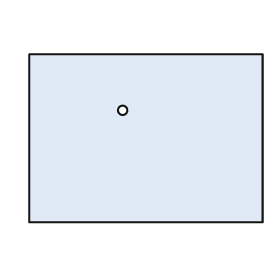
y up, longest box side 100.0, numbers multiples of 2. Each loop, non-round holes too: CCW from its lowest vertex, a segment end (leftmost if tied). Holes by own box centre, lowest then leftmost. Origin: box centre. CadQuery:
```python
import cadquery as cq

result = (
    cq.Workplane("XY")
    .moveTo(-50.0, -36.0)
    .lineTo(50.0, -36.0)
    .lineTo(50.0, 36.0)
    .lineTo(-50.0, 36.0)
    .close()
    .moveTo(-10.0, 12.0)
    .circle(2.0)
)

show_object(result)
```